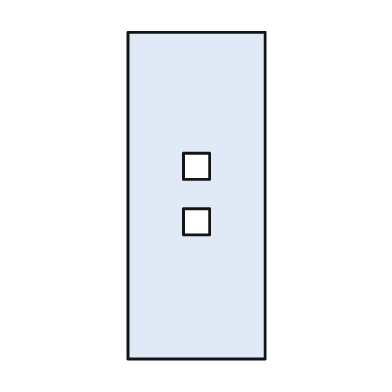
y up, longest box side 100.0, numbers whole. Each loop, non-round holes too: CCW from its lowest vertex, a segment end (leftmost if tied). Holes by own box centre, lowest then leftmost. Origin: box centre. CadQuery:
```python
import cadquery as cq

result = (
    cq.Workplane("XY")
    .moveTo(-21.0, -50.0)
    .lineTo(21.0, -50.0)
    .lineTo(21.0, 50.0)
    .lineTo(-21.0, 50.0)
    .close()
    .moveTo(-4.0, -12.0)
    .lineTo(4.0, -12.0)
    .lineTo(4.0, -4.0)
    .lineTo(-4.0, -4.0)
    .close()
    .moveTo(-4.0, 5.0)
    .lineTo(4.0, 5.0)
    .lineTo(4.0, 13.0)
    .lineTo(-4.0, 13.0)
    .close()
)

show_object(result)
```